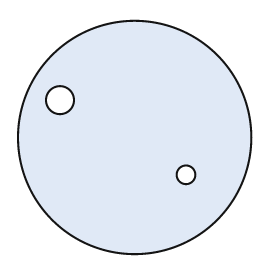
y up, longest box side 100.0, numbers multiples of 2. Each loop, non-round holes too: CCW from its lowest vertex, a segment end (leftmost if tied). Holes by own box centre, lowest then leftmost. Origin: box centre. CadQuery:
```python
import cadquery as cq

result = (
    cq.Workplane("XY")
    .moveTo(0.0, 0.0)
    .circle(50.0)
    .moveTo(22.0, -16.0)
    .circle(4.0)
    .moveTo(-32.0, 16.0)
    .circle(6.0)
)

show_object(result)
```